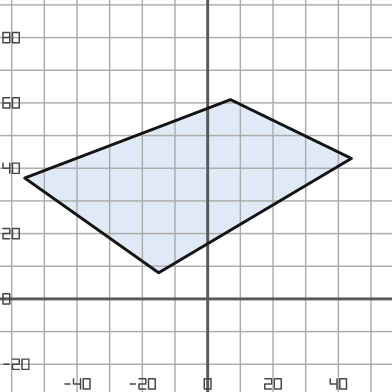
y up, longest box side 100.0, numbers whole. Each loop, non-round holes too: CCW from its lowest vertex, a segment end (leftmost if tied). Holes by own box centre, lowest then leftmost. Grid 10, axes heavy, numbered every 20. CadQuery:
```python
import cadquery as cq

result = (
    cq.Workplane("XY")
    .moveTo(-15.0, 8.0)
    .lineTo(44.0, 43.0)
    .lineTo(7.0, 61.0)
    .lineTo(-56.0, 37.0)
    .close()
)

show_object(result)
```